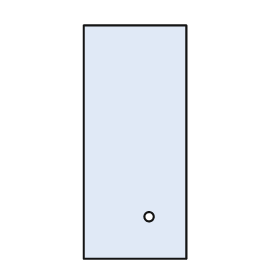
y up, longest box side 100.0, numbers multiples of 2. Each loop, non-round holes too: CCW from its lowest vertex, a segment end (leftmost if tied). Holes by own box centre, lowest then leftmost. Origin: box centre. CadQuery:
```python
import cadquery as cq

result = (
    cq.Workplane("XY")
    .moveTo(-22.0, -50.0)
    .lineTo(22.0, -50.0)
    .lineTo(22.0, 50.0)
    .lineTo(-22.0, 50.0)
    .close()
    .moveTo(6.0, -32.0)
    .circle(2.0)
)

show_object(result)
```